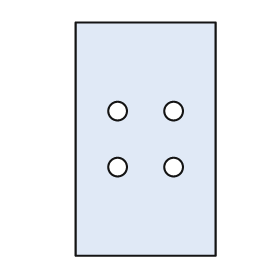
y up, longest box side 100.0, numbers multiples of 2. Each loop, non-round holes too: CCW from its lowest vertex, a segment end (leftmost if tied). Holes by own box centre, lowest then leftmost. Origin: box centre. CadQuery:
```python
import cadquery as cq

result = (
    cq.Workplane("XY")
    .moveTo(-30.0, -50.0)
    .lineTo(30.0, -50.0)
    .lineTo(30.0, 50.0)
    .lineTo(-30.0, 50.0)
    .close()
    .moveTo(-12.0, -12.0)
    .circle(4.0)
    .moveTo(12.0, -12.0)
    .circle(4.0)
    .moveTo(-12.0, 12.0)
    .circle(4.0)
    .moveTo(12.0, 12.0)
    .circle(4.0)
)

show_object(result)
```